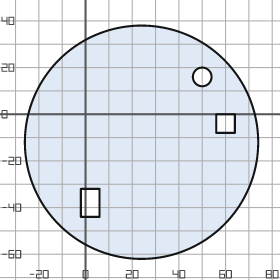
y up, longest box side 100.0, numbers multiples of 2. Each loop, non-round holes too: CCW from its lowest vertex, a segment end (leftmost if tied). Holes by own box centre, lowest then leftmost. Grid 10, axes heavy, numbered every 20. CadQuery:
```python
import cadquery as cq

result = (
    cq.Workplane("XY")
    .moveTo(24.0, -12.0)
    .circle(50.0)
    .moveTo(-2.0, -44.0)
    .lineTo(6.0, -44.0)
    .lineTo(6.0, -32.0)
    .lineTo(-2.0, -32.0)
    .close()
    .moveTo(56.0, -8.0)
    .lineTo(64.0, -8.0)
    .lineTo(64.0, 0.0)
    .lineTo(56.0, 0.0)
    .close()
    .moveTo(50.0, 16.0)
    .circle(4.0)
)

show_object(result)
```